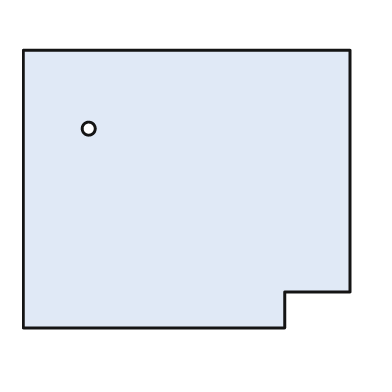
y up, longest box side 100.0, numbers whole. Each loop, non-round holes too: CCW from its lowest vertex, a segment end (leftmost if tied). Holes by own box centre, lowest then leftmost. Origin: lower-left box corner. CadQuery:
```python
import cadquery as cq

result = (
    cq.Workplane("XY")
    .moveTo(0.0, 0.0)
    .lineTo(80.0, 0.0)
    .lineTo(80.0, 11.0)
    .lineTo(100.0, 11.0)
    .lineTo(100.0, 85.0)
    .lineTo(0.0, 85.0)
    .close()
    .moveTo(20.0, 61.0)
    .circle(2.0)
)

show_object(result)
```